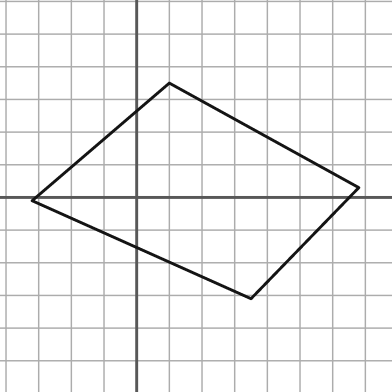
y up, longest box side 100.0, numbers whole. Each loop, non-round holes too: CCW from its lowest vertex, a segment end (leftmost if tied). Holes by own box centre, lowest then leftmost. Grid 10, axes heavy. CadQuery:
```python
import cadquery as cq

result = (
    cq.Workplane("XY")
    .moveTo(35.0, -31.0)
    .lineTo(68.0, 3.0)
    .lineTo(10.0, 35.0)
    .lineTo(-32.0, -1.0)
    .close()
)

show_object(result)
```